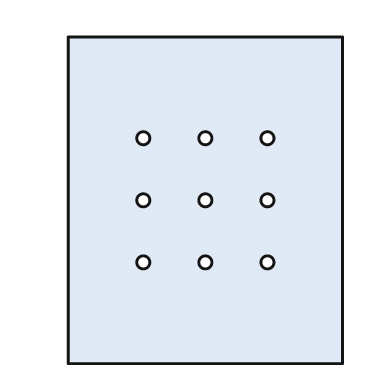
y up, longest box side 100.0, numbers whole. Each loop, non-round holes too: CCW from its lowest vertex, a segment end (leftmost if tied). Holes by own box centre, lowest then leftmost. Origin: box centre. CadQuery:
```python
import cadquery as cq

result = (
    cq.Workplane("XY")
    .moveTo(-42.0, -50.0)
    .lineTo(42.0, -50.0)
    .lineTo(42.0, 50.0)
    .lineTo(-42.0, 50.0)
    .close()
    .moveTo(-19.0, -19.0)
    .circle(2.0)
    .moveTo(0.0, -19.0)
    .circle(2.0)
    .moveTo(19.0, -19.0)
    .circle(2.0)
    .moveTo(-19.0, 0.0)
    .circle(2.0)
    .moveTo(0.0, 0.0)
    .circle(2.0)
    .moveTo(19.0, 0.0)
    .circle(2.0)
    .moveTo(-19.0, 19.0)
    .circle(2.0)
    .moveTo(0.0, 19.0)
    .circle(2.0)
    .moveTo(19.0, 19.0)
    .circle(2.0)
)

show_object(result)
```